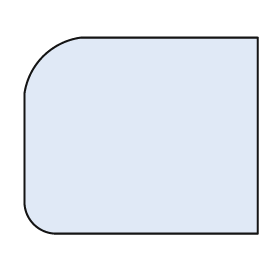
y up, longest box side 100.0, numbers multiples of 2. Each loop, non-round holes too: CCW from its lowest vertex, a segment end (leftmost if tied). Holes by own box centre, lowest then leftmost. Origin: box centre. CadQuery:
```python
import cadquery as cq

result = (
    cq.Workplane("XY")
    .moveTo(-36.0, -42.0)
    .lineTo(50.0, -42.0)
    .lineTo(50.0, 42.0)
    .lineTo(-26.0, 42.0)
    .threePointArc((-42.0, 34.0), (-50.0, 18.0))
    .lineTo(-50.0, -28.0)
    .threePointArc((-46.0, -38.0), (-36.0, -42.0))
    .close()
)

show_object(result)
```